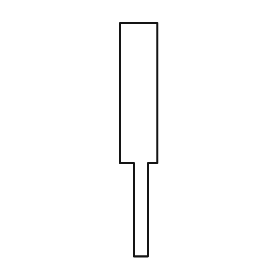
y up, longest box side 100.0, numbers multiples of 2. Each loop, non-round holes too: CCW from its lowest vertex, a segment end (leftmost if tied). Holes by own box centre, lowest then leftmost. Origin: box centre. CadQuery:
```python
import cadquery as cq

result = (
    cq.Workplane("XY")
    .moveTo(-2.0, -50.0)
    .lineTo(4.0, -50.0)
    .lineTo(4.0, -10.0)
    .lineTo(8.0, -10.0)
    .lineTo(8.0, 50.0)
    .lineTo(-8.0, 50.0)
    .lineTo(-8.0, -10.0)
    .lineTo(-2.0, -10.0)
    .close()
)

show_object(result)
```